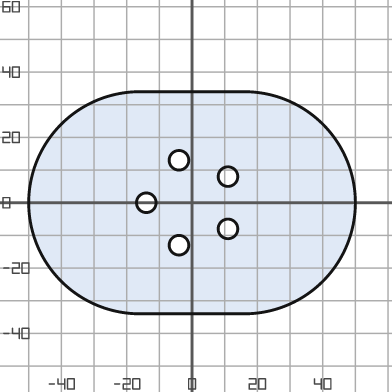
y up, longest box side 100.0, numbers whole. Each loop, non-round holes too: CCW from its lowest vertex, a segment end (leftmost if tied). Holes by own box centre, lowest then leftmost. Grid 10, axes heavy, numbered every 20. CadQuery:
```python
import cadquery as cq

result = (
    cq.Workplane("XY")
    .moveTo(-16.0, -34.0)
    .lineTo(16.0, -34.0)
    .threePointArc((50.0, 0.0), (16.0, 34.0))
    .lineTo(-16.0, 34.0)
    .threePointArc((-50.0, 0.0), (-16.0, -34.0))
    .close()
    .moveTo(-4.0, -13.0)
    .circle(3.0)
    .moveTo(11.0, -8.0)
    .circle(3.0)
    .moveTo(-14.0, 0.0)
    .circle(3.0)
    .moveTo(11.0, 8.0)
    .circle(3.0)
    .moveTo(-4.0, 13.0)
    .circle(3.0)
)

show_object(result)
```